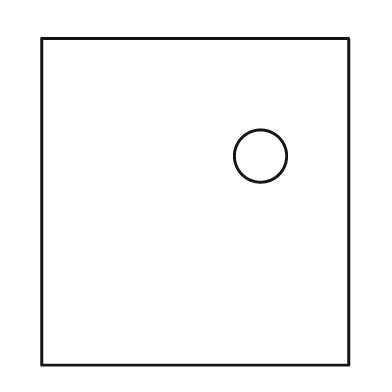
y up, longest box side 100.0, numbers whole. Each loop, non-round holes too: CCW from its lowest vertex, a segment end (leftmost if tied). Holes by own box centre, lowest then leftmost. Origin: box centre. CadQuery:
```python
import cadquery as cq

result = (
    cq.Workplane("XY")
    .moveTo(-47.0, -50.0)
    .lineTo(47.0, -50.0)
    .lineTo(47.0, 50.0)
    .lineTo(-47.0, 50.0)
    .close()
    .moveTo(20.0, 14.0)
    .circle(8.0)
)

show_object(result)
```